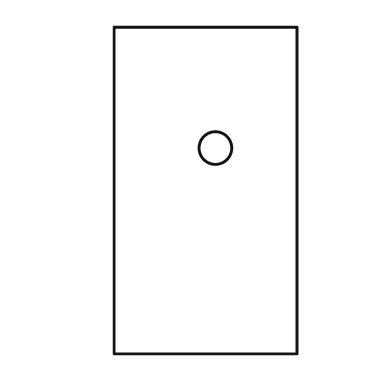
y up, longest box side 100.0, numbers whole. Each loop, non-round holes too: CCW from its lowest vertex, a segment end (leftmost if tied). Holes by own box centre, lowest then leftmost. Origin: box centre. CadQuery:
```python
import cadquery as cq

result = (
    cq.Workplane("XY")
    .moveTo(-28.0, -50.0)
    .lineTo(28.0, -50.0)
    .lineTo(28.0, 50.0)
    .lineTo(-28.0, 50.0)
    .close()
    .moveTo(3.0, 13.0)
    .circle(5.0)
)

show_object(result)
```